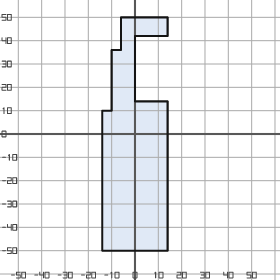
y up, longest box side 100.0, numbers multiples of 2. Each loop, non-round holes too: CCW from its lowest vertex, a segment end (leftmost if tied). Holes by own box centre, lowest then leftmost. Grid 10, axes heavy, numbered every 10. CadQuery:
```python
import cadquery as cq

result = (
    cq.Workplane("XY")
    .moveTo(-14.0, -50.0)
    .lineTo(14.0, -50.0)
    .lineTo(14.0, 14.0)
    .lineTo(0.0, 14.0)
    .lineTo(0.0, 42.0)
    .lineTo(14.0, 42.0)
    .lineTo(14.0, 50.0)
    .lineTo(-6.0, 50.0)
    .lineTo(-6.0, 36.0)
    .lineTo(-10.0, 36.0)
    .lineTo(-10.0, 10.0)
    .lineTo(-14.0, 10.0)
    .close()
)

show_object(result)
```